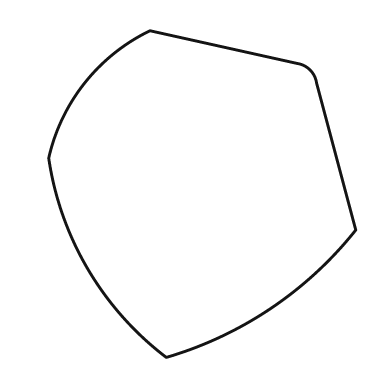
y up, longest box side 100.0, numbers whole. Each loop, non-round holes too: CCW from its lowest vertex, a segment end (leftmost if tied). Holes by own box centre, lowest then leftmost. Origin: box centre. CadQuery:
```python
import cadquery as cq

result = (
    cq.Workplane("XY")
    .moveTo(-11.0, -50.0)
    .threePointArc((21.0, -35.0), (47.0, -11.0))
    .lineTo(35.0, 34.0)
    .threePointArc((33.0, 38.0), (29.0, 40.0))
    .lineTo(-16.0, 50.0)
    .threePointArc((-36.0, 34.0), (-47.0, 11.0))
    .threePointArc((-35.0, -23.0), (-11.0, -50.0))
    .close()
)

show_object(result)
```